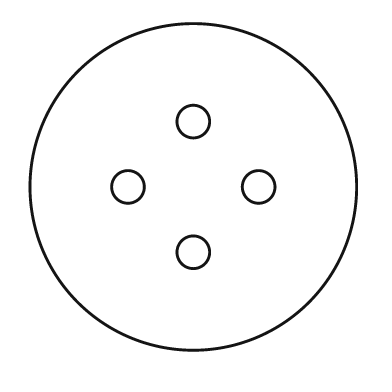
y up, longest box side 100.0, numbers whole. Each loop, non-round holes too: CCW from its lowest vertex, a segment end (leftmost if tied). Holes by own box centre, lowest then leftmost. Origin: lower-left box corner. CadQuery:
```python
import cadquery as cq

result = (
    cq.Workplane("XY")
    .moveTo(50.0, 50.0)
    .circle(50.0)
    .moveTo(50.0, 30.0)
    .circle(5.0)
    .moveTo(30.0, 50.0)
    .circle(5.0)
    .moveTo(70.0, 50.0)
    .circle(5.0)
    .moveTo(50.0, 70.0)
    .circle(5.0)
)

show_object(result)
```